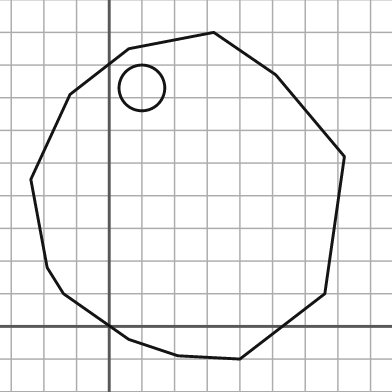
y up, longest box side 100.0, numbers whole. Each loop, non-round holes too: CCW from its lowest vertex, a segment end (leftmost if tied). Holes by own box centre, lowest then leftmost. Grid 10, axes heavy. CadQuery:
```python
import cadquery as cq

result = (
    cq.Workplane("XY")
    .moveTo(40.0, -10.0)
    .lineTo(66.0, 10.0)
    .lineTo(72.0, 52.0)
    .lineTo(51.0, 77.0)
    .lineTo(32.0, 90.0)
    .lineTo(6.0, 85.0)
    .lineTo(-12.0, 71.0)
    .lineTo(-24.0, 45.0)
    .lineTo(-19.0, 18.0)
    .lineTo(-14.0, 10.0)
    .lineTo(6.0, -4.0)
    .lineTo(21.0, -9.0)
    .close()
    .moveTo(10.0, 73.0)
    .circle(7.0)
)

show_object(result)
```